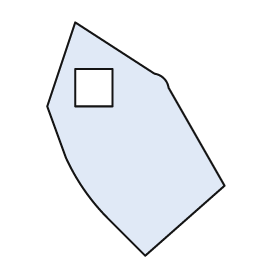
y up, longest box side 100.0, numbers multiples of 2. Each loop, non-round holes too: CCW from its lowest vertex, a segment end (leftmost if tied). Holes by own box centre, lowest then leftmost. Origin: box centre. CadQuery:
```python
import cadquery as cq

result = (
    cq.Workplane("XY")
    .moveTo(4.0, -50.0)
    .lineTo(38.0, -20.0)
    .lineTo(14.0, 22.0)
    .threePointArc((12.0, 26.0), (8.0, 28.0))
    .lineTo(-26.0, 50.0)
    .lineTo(-38.0, 14.0)
    .lineTo(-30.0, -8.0)
    .threePointArc((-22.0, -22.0), (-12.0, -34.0))
    .close()
    .moveTo(-26.0, 14.0)
    .lineTo(-10.0, 14.0)
    .lineTo(-10.0, 30.0)
    .lineTo(-26.0, 30.0)
    .close()
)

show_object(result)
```